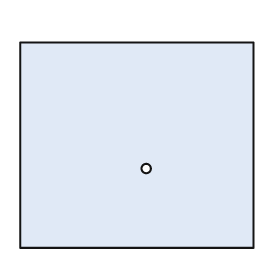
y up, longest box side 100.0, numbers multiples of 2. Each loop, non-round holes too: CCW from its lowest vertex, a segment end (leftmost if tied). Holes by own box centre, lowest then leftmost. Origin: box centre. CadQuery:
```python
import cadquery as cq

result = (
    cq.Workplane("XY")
    .moveTo(-50.0, -44.0)
    .lineTo(50.0, -44.0)
    .lineTo(50.0, 44.0)
    .lineTo(-50.0, 44.0)
    .close()
    .moveTo(4.0, -10.0)
    .circle(2.0)
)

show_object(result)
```